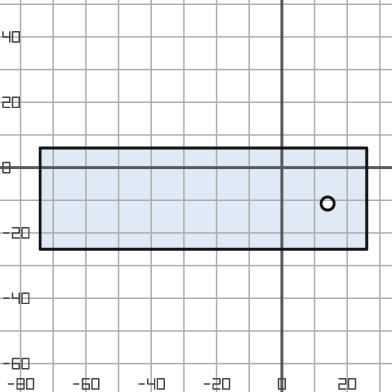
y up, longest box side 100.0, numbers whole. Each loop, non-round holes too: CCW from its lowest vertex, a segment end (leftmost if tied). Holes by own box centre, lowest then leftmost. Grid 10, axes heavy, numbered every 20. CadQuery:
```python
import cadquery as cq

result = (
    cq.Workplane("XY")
    .moveTo(-74.0, -25.0)
    .lineTo(26.0, -25.0)
    .lineTo(26.0, 6.0)
    .lineTo(-74.0, 6.0)
    .close()
    .moveTo(14.0, -11.0)
    .circle(2.0)
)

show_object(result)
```